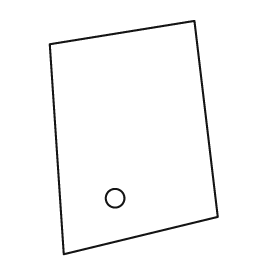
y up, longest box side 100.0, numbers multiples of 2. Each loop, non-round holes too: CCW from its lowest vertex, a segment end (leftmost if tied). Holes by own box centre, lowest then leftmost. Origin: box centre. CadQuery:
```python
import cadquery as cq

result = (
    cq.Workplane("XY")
    .moveTo(-30.0, -50.0)
    .lineTo(36.0, -34.0)
    .lineTo(26.0, 50.0)
    .lineTo(-36.0, 40.0)
    .close()
    .moveTo(-8.0, -26.0)
    .circle(4.0)
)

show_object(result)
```